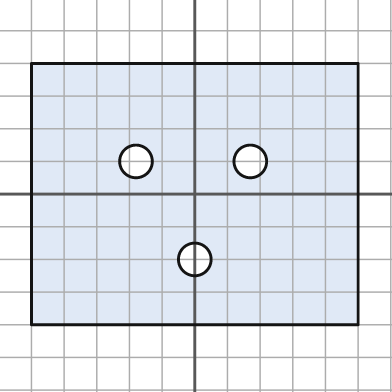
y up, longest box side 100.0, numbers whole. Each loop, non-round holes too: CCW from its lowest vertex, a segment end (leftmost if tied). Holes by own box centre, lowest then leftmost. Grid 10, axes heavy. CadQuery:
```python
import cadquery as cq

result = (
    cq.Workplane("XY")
    .moveTo(-50.0, -40.0)
    .lineTo(50.0, -40.0)
    .lineTo(50.0, 40.0)
    .lineTo(-50.0, 40.0)
    .close()
    .moveTo(0.0, -20.0)
    .circle(5.0)
    .moveTo(-18.0, 10.0)
    .circle(5.0)
    .moveTo(17.0, 10.0)
    .circle(5.0)
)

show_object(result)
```